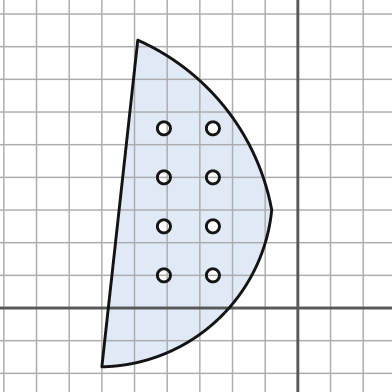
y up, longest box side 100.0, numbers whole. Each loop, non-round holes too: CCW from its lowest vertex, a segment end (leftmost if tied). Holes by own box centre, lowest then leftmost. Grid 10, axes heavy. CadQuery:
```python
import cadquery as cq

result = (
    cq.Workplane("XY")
    .moveTo(-60.0, -18.0)
    .threePointArc((-25.0, -4.0), (-8.0, 30.0))
    .threePointArc((-22.0, 61.0), (-49.0, 82.0))
    .close()
    .moveTo(-41.0, 10.0)
    .circle(2.0)
    .moveTo(-26.0, 10.0)
    .circle(2.0)
    .moveTo(-41.0, 25.0)
    .circle(2.0)
    .moveTo(-26.0, 25.0)
    .circle(2.0)
    .moveTo(-41.0, 40.0)
    .circle(2.0)
    .moveTo(-26.0, 40.0)
    .circle(2.0)
    .moveTo(-41.0, 55.0)
    .circle(2.0)
    .moveTo(-26.0, 55.0)
    .circle(2.0)
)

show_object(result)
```